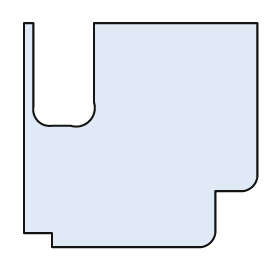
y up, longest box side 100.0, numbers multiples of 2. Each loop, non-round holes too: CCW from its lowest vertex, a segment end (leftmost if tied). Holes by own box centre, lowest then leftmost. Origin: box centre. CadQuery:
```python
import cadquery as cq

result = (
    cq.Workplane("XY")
    .moveTo(-38.0, -48.0)
    .lineTo(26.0, -48.0)
    .threePointArc((30.0, -46.0), (32.0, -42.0))
    .lineTo(32.0, -24.0)
    .lineTo(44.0, -24.0)
    .threePointArc((48.0, -22.0), (50.0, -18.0))
    .lineTo(50.0, 48.0)
    .lineTo(-20.0, 48.0)
    .lineTo(-20.0, 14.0)
    .threePointArc((-22.0, 6.0), (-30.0, 4.0))
    .lineTo(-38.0, 4.0)
    .threePointArc((-44.0, 6.0), (-46.0, 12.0))
    .lineTo(-46.0, 48.0)
    .lineTo(-50.0, 48.0)
    .lineTo(-50.0, -42.0)
    .lineTo(-38.0, -42.0)
    .close()
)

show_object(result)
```